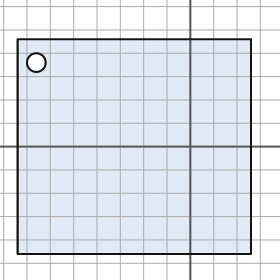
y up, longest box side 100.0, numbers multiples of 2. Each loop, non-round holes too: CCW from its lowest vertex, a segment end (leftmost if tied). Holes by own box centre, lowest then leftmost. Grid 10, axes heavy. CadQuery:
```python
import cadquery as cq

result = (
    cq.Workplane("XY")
    .moveTo(-74.0, -46.0)
    .lineTo(26.0, -46.0)
    .lineTo(26.0, 46.0)
    .lineTo(-74.0, 46.0)
    .close()
    .moveTo(-66.0, 36.0)
    .circle(4.0)
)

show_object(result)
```